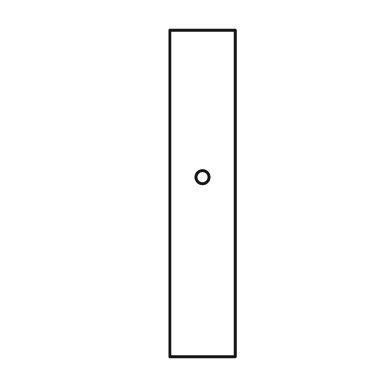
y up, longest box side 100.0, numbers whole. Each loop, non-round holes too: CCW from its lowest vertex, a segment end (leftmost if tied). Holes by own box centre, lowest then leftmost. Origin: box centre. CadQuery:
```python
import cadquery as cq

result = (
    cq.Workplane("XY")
    .moveTo(-10.0, -50.0)
    .lineTo(10.0, -50.0)
    .lineTo(10.0, 50.0)
    .lineTo(-10.0, 50.0)
    .close()
    .moveTo(0.0, 5.0)
    .circle(2.0)
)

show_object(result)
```